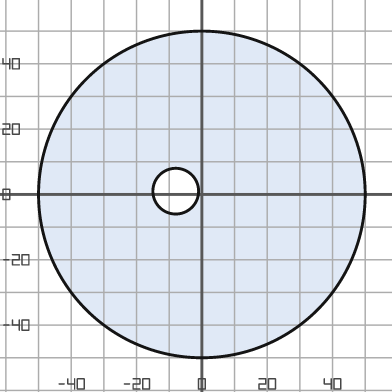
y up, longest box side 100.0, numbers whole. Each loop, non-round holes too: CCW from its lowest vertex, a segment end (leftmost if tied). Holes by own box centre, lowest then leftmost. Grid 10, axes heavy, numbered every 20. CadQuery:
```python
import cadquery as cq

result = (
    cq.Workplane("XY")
    .moveTo(0.0, 0.0)
    .circle(50.0)
    .moveTo(-8.0, 1.0)
    .circle(7.0)
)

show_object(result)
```